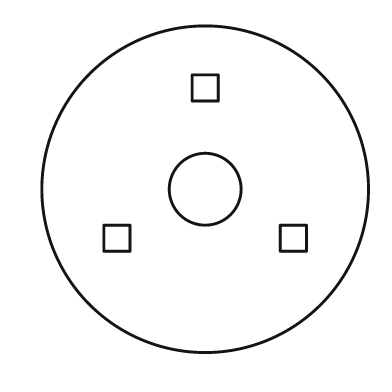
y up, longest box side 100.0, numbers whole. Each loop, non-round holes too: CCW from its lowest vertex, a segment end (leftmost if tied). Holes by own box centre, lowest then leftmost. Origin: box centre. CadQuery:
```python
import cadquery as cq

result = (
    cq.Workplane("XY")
    .moveTo(0.0, 0.0)
    .circle(50.0)
    .moveTo(-31.0, -19.0)
    .lineTo(-23.0, -19.0)
    .lineTo(-23.0, -11.0)
    .lineTo(-31.0, -11.0)
    .close()
    .moveTo(23.0, -19.0)
    .lineTo(31.0, -19.0)
    .lineTo(31.0, -11.0)
    .lineTo(23.0, -11.0)
    .close()
    .moveTo(0.0, 0.0)
    .circle(11.0)
    .moveTo(-4.0, 27.0)
    .lineTo(4.0, 27.0)
    .lineTo(4.0, 35.0)
    .lineTo(-4.0, 35.0)
    .close()
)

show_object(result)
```